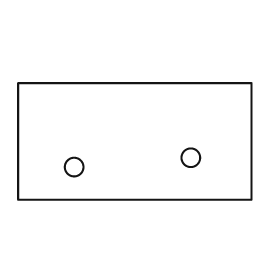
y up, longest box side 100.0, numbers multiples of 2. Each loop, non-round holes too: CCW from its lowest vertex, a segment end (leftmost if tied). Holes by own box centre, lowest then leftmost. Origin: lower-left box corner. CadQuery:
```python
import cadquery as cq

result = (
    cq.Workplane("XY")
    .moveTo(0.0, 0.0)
    .lineTo(100.0, 0.0)
    .lineTo(100.0, 50.0)
    .lineTo(0.0, 50.0)
    .close()
    .moveTo(24.0, 14.0)
    .circle(4.0)
    .moveTo(74.0, 18.0)
    .circle(4.0)
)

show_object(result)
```